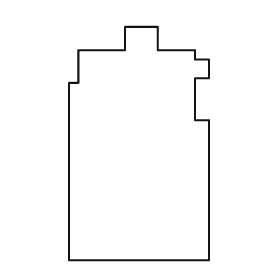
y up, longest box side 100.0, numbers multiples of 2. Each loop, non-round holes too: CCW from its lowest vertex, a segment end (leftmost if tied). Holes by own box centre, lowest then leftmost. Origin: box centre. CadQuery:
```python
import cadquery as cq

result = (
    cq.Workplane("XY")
    .moveTo(-30.0, -50.0)
    .lineTo(30.0, -50.0)
    .lineTo(30.0, 10.0)
    .lineTo(24.0, 10.0)
    .lineTo(24.0, 28.0)
    .lineTo(30.0, 28.0)
    .lineTo(30.0, 36.0)
    .lineTo(24.0, 36.0)
    .lineTo(24.0, 40.0)
    .lineTo(8.0, 40.0)
    .lineTo(8.0, 50.0)
    .lineTo(-6.0, 50.0)
    .lineTo(-6.0, 40.0)
    .lineTo(-26.0, 40.0)
    .lineTo(-26.0, 26.0)
    .lineTo(-30.0, 26.0)
    .close()
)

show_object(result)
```